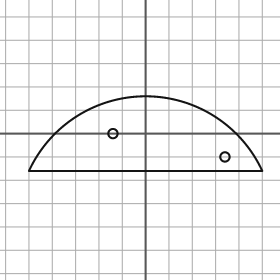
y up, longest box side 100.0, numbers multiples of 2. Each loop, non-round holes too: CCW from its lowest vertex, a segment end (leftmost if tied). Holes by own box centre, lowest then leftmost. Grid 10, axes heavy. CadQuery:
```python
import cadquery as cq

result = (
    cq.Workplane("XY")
    .moveTo(-50.0, -16.0)
    .lineTo(50.0, -16.0)
    .threePointArc((0.0, 16.0), (-50.0, -16.0))
    .close()
    .moveTo(34.0, -10.0)
    .circle(2.0)
    .moveTo(-14.0, 0.0)
    .circle(2.0)
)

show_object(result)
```